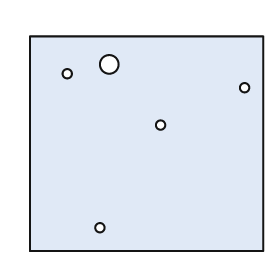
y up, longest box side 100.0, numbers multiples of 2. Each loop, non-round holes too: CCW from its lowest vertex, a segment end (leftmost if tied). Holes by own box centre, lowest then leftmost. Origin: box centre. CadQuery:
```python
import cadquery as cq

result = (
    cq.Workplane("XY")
    .moveTo(-50.0, -46.0)
    .lineTo(50.0, -46.0)
    .lineTo(50.0, 46.0)
    .lineTo(-50.0, 46.0)
    .close()
    .moveTo(-20.0, -36.0)
    .circle(2.0)
    .moveTo(6.0, 8.0)
    .circle(2.0)
    .moveTo(42.0, 24.0)
    .circle(2.0)
    .moveTo(-34.0, 30.0)
    .circle(2.0)
    .moveTo(-16.0, 34.0)
    .circle(4.0)
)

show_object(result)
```